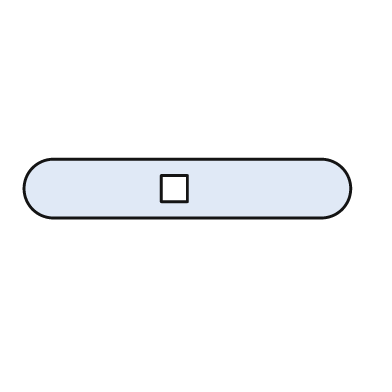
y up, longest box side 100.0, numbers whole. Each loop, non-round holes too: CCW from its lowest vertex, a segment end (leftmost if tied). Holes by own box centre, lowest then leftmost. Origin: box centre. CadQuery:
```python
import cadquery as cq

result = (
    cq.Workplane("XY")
    .moveTo(-41.0, -9.0)
    .lineTo(41.0, -9.0)
    .threePointArc((50.0, 0.0), (41.0, 9.0))
    .lineTo(-41.0, 9.0)
    .threePointArc((-50.0, 0.0), (-41.0, -9.0))
    .close()
    .moveTo(-8.0, -4.0)
    .lineTo(0.0, -4.0)
    .lineTo(0.0, 4.0)
    .lineTo(-8.0, 4.0)
    .close()
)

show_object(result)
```